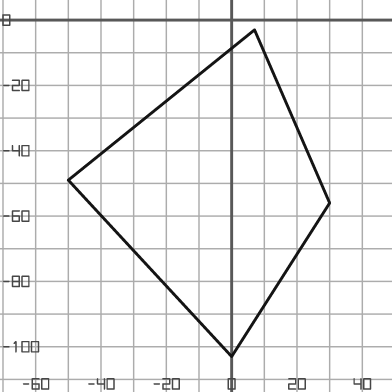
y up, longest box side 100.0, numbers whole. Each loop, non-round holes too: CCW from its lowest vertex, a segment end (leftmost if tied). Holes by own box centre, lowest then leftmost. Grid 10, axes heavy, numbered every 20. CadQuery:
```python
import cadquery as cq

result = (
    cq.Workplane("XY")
    .moveTo(0.0, -103.0)
    .lineTo(30.0, -56.0)
    .lineTo(7.0, -3.0)
    .lineTo(-50.0, -49.0)
    .close()
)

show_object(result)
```